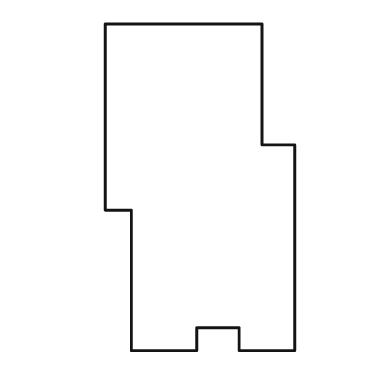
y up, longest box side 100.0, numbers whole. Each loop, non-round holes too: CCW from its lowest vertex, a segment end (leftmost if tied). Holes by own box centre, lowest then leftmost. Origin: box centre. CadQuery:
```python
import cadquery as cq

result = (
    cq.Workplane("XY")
    .moveTo(-21.0, -50.0)
    .lineTo(-1.0, -50.0)
    .lineTo(-1.0, -43.0)
    .lineTo(12.0, -43.0)
    .lineTo(12.0, -50.0)
    .lineTo(29.0, -50.0)
    .lineTo(29.0, 13.0)
    .lineTo(19.0, 13.0)
    .lineTo(19.0, 50.0)
    .lineTo(-29.0, 50.0)
    .lineTo(-29.0, -7.0)
    .lineTo(-21.0, -7.0)
    .close()
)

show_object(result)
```